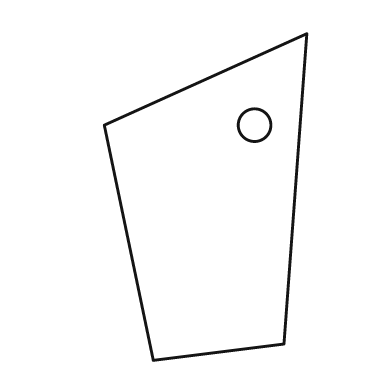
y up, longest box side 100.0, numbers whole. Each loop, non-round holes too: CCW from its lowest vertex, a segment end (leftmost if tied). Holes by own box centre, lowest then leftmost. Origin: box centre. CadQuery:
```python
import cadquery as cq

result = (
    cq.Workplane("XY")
    .moveTo(-16.0, -50.0)
    .lineTo(24.0, -45.0)
    .lineTo(31.0, 50.0)
    .lineTo(-31.0, 22.0)
    .close()
    .moveTo(15.0, 22.0)
    .circle(5.0)
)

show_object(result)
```